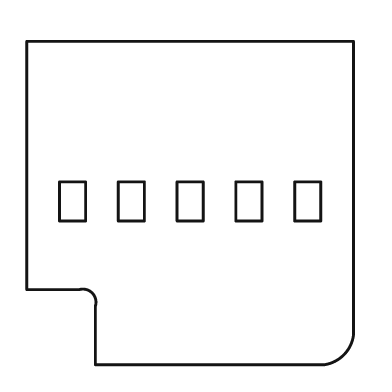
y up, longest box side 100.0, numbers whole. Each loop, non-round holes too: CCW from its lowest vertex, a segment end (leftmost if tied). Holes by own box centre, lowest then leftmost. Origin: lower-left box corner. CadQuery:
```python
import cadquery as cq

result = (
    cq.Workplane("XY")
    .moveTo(21.0, 0.0)
    .lineTo(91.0, 0.0)
    .threePointArc((97.0, 3.0), (100.0, 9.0))
    .lineTo(100.0, 99.0)
    .lineTo(0.0, 99.0)
    .lineTo(0.0, 23.0)
    .lineTo(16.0, 23.0)
    .threePointArc((20.0, 22.0), (21.0, 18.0))
    .close()
    .moveTo(10.0, 44.0)
    .lineTo(18.0, 44.0)
    .lineTo(18.0, 56.0)
    .lineTo(10.0, 56.0)
    .close()
    .moveTo(28.0, 44.0)
    .lineTo(36.0, 44.0)
    .lineTo(36.0, 56.0)
    .lineTo(28.0, 56.0)
    .close()
    .moveTo(46.0, 44.0)
    .lineTo(54.0, 44.0)
    .lineTo(54.0, 56.0)
    .lineTo(46.0, 56.0)
    .close()
    .moveTo(64.0, 44.0)
    .lineTo(72.0, 44.0)
    .lineTo(72.0, 56.0)
    .lineTo(64.0, 56.0)
    .close()
    .moveTo(82.0, 44.0)
    .lineTo(90.0, 44.0)
    .lineTo(90.0, 56.0)
    .lineTo(82.0, 56.0)
    .close()
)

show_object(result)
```